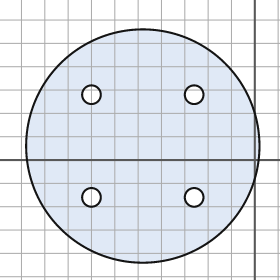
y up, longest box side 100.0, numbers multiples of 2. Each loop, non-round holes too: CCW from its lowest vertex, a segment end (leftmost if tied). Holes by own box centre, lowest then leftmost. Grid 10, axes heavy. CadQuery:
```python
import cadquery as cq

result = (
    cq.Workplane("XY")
    .moveTo(-48.0, 6.0)
    .circle(50.0)
    .moveTo(-70.0, -16.0)
    .circle(4.0)
    .moveTo(-26.0, -16.0)
    .circle(4.0)
    .moveTo(-70.0, 28.0)
    .circle(4.0)
    .moveTo(-26.0, 28.0)
    .circle(4.0)
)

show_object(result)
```